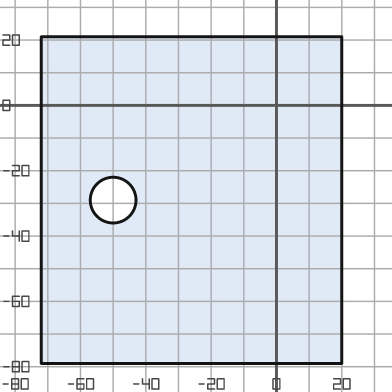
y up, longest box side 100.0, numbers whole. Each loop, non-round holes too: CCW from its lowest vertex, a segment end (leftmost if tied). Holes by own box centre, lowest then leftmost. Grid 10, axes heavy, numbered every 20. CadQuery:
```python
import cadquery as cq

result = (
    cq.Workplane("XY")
    .moveTo(-72.0, -79.0)
    .lineTo(20.0, -79.0)
    .lineTo(20.0, 21.0)
    .lineTo(-72.0, 21.0)
    .close()
    .moveTo(-50.0, -29.0)
    .circle(7.0)
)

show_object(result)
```